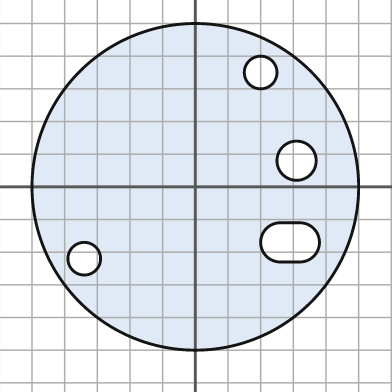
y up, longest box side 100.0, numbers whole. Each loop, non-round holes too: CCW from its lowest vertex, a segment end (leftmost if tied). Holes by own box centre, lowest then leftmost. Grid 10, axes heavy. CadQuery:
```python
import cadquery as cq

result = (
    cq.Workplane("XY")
    .moveTo(0.0, 0.0)
    .circle(50.0)
    .moveTo(-34.0, -22.0)
    .circle(5.0)
    .moveTo(26.0, -23.0)
    .lineTo(32.0, -23.0)
    .threePointArc((38.0, -17.0), (32.0, -11.0))
    .lineTo(26.0, -11.0)
    .threePointArc((20.0, -17.0), (26.0, -23.0))
    .close()
    .moveTo(31.0, 8.0)
    .circle(6.0)
    .moveTo(20.0, 35.0)
    .circle(5.0)
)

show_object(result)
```